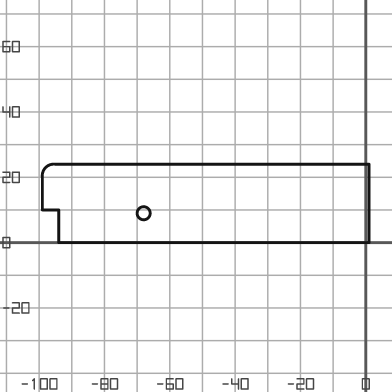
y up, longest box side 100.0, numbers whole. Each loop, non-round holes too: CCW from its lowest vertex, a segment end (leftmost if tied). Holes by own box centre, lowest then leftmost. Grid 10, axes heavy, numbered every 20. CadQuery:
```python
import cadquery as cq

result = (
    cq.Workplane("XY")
    .moveTo(-94.0, 0.0)
    .lineTo(1.0, 0.0)
    .lineTo(1.0, 24.0)
    .lineTo(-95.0, 24.0)
    .threePointArc((-98.0, 23.0), (-99.0, 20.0))
    .lineTo(-99.0, 10.0)
    .lineTo(-94.0, 10.0)
    .close()
    .moveTo(-68.0, 9.0)
    .circle(2.0)
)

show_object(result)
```